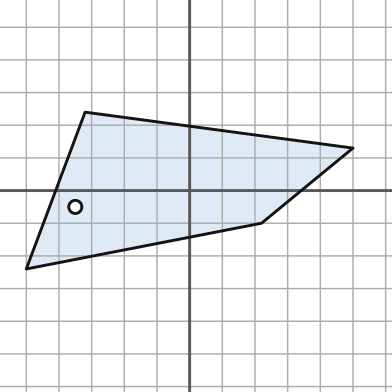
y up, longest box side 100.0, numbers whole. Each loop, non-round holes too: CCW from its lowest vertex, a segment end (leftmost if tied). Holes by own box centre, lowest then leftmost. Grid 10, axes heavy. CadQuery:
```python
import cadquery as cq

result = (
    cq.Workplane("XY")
    .moveTo(-50.0, -24.0)
    .lineTo(22.0, -10.0)
    .lineTo(50.0, 13.0)
    .lineTo(-32.0, 24.0)
    .close()
    .moveTo(-35.0, -5.0)
    .circle(2.0)
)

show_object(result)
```